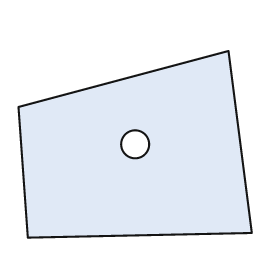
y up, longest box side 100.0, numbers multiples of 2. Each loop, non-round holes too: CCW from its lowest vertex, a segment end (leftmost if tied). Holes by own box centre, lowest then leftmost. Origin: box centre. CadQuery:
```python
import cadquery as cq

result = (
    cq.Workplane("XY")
    .moveTo(-46.0, -40.0)
    .lineTo(50.0, -38.0)
    .lineTo(40.0, 40.0)
    .lineTo(-50.0, 16.0)
    .close()
    .moveTo(0.0, 0.0)
    .circle(6.0)
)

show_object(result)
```